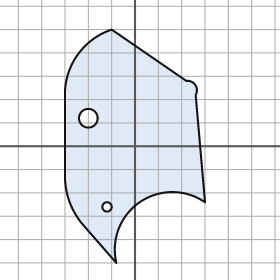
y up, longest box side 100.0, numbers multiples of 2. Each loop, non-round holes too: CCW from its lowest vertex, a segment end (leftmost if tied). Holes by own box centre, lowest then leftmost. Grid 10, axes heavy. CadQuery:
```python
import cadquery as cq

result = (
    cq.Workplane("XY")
    .moveTo(-8.0, -50.0)
    .threePointArc((2.0, -24.0), (30.0, -24.0))
    .lineTo(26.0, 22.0)
    .threePointArc((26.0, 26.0), (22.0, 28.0))
    .lineTo(-10.0, 50.0)
    .threePointArc((-24.0, 40.0), (-30.0, 24.0))
    .lineTo(-30.0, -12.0)
    .threePointArc((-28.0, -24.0), (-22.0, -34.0))
    .close()
    .moveTo(-12.0, -26.0)
    .circle(2.0)
    .moveTo(-20.0, 12.0)
    .circle(4.0)
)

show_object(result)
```